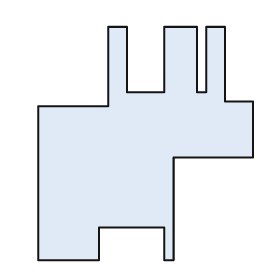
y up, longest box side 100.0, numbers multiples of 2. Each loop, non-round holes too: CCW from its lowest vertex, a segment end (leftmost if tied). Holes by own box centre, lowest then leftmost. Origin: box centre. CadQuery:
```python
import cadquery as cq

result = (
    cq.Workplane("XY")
    .moveTo(-46.0, -50.0)
    .lineTo(-20.0, -50.0)
    .lineTo(-20.0, -36.0)
    .lineTo(8.0, -36.0)
    .lineTo(8.0, -50.0)
    .lineTo(12.0, -50.0)
    .lineTo(12.0, -6.0)
    .lineTo(46.0, -6.0)
    .lineTo(46.0, 18.0)
    .lineTo(34.0, 18.0)
    .lineTo(34.0, 50.0)
    .lineTo(26.0, 50.0)
    .lineTo(26.0, 22.0)
    .lineTo(22.0, 22.0)
    .lineTo(22.0, 50.0)
    .lineTo(8.0, 50.0)
    .lineTo(8.0, 22.0)
    .lineTo(-8.0, 22.0)
    .lineTo(-8.0, 50.0)
    .lineTo(-16.0, 50.0)
    .lineTo(-16.0, 16.0)
    .lineTo(-46.0, 16.0)
    .close()
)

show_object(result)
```